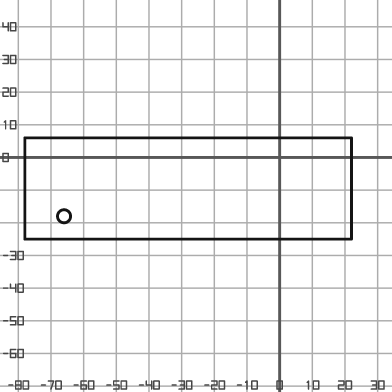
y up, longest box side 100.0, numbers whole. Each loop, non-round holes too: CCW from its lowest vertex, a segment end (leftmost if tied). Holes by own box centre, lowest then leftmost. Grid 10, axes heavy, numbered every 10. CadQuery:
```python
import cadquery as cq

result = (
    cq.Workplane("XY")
    .moveTo(-78.0, -25.0)
    .lineTo(22.0, -25.0)
    .lineTo(22.0, 6.0)
    .lineTo(-78.0, 6.0)
    .close()
    .moveTo(-66.0, -18.0)
    .circle(2.0)
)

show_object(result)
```